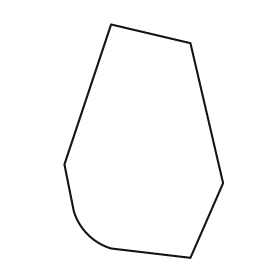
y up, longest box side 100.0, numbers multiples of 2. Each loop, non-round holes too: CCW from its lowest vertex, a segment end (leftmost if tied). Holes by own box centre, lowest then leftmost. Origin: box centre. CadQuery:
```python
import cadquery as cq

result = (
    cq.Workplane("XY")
    .moveTo(20.0, -50.0)
    .lineTo(34.0, -18.0)
    .lineTo(20.0, 42.0)
    .lineTo(-14.0, 50.0)
    .lineTo(-34.0, -10.0)
    .lineTo(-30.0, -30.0)
    .threePointArc((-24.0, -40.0), (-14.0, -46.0))
    .close()
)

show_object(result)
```